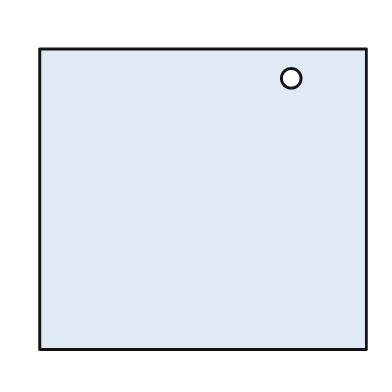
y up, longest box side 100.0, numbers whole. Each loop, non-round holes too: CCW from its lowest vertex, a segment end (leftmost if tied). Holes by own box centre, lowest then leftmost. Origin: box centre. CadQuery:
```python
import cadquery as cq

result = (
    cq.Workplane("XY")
    .moveTo(-50.0, -46.0)
    .lineTo(50.0, -46.0)
    .lineTo(50.0, 46.0)
    .lineTo(-50.0, 46.0)
    .close()
    .moveTo(27.0, 37.0)
    .circle(3.0)
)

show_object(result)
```